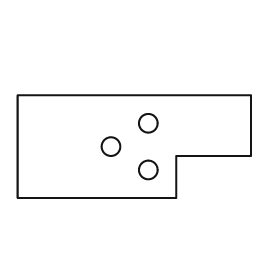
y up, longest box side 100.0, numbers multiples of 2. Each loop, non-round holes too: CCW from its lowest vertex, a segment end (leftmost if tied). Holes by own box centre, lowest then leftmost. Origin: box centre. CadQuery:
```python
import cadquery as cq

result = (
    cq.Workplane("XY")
    .moveTo(-50.0, -22.0)
    .lineTo(18.0, -22.0)
    .lineTo(18.0, -4.0)
    .lineTo(50.0, -4.0)
    .lineTo(50.0, 22.0)
    .lineTo(-50.0, 22.0)
    .close()
    .moveTo(6.0, -10.0)
    .circle(4.0)
    .moveTo(-10.0, 0.0)
    .circle(4.0)
    .moveTo(6.0, 10.0)
    .circle(4.0)
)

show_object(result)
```